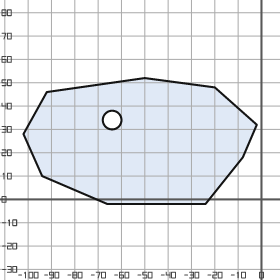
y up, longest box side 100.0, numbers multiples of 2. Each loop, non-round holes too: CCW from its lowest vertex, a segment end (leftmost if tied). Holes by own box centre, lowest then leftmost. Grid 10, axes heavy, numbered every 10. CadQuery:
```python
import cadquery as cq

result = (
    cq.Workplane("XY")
    .moveTo(-66.0, -2.0)
    .lineTo(-24.0, -2.0)
    .lineTo(-8.0, 18.0)
    .lineTo(-2.0, 32.0)
    .lineTo(-20.0, 48.0)
    .lineTo(-50.0, 52.0)
    .lineTo(-92.0, 46.0)
    .lineTo(-102.0, 28.0)
    .lineTo(-94.0, 10.0)
    .close()
    .moveTo(-64.0, 34.0)
    .circle(4.0)
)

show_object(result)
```